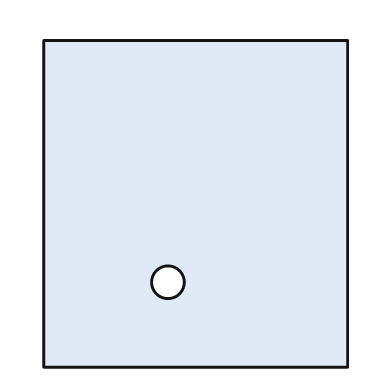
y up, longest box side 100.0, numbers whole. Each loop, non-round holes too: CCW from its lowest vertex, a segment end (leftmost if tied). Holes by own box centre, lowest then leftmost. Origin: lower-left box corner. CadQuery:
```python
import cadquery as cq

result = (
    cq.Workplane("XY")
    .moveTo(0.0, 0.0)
    .lineTo(93.0, 0.0)
    .lineTo(93.0, 100.0)
    .lineTo(0.0, 100.0)
    .close()
    .moveTo(38.0, 26.0)
    .circle(5.0)
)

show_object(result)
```